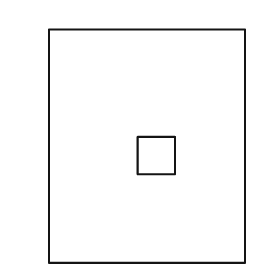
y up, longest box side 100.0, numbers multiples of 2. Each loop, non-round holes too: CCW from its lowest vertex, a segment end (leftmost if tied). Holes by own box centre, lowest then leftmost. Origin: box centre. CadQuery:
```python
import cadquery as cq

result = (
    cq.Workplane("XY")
    .moveTo(-42.0, -50.0)
    .lineTo(42.0, -50.0)
    .lineTo(42.0, 50.0)
    .lineTo(-42.0, 50.0)
    .close()
    .moveTo(-4.0, -12.0)
    .lineTo(12.0, -12.0)
    .lineTo(12.0, 4.0)
    .lineTo(-4.0, 4.0)
    .close()
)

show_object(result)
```